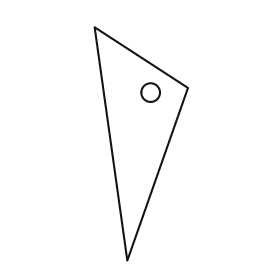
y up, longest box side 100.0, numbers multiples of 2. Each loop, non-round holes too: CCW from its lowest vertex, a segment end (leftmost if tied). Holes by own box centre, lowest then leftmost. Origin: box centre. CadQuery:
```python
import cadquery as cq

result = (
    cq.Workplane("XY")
    .moveTo(-6.0, -50.0)
    .lineTo(20.0, 24.0)
    .lineTo(-20.0, 50.0)
    .close()
    .moveTo(4.0, 22.0)
    .circle(4.0)
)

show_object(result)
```